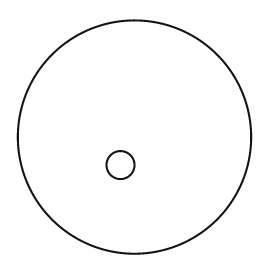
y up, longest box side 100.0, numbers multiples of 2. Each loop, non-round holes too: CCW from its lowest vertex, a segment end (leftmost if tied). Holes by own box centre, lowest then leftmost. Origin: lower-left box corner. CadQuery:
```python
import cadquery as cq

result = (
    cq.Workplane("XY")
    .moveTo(50.0, 50.0)
    .circle(50.0)
    .moveTo(44.0, 38.0)
    .circle(6.0)
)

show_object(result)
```